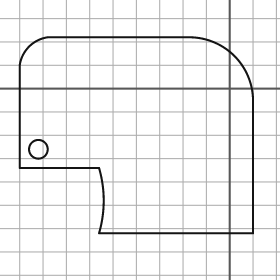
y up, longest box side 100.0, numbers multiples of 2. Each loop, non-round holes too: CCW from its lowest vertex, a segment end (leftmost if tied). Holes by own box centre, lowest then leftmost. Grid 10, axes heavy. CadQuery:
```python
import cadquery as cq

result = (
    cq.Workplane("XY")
    .moveTo(-56.0, -62.0)
    .lineTo(10.0, -62.0)
    .lineTo(10.0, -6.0)
    .threePointArc((2.0, 14.0), (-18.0, 22.0))
    .lineTo(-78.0, 22.0)
    .threePointArc((-86.0, 18.0), (-90.0, 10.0))
    .lineTo(-90.0, -34.0)
    .lineTo(-56.0, -34.0)
    .threePointArc((-54.0, -48.0), (-56.0, -62.0))
    .close()
    .moveTo(-82.0, -26.0)
    .circle(4.0)
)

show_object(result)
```